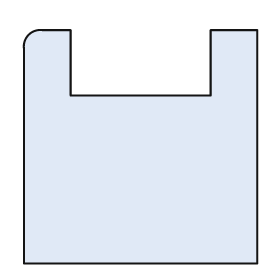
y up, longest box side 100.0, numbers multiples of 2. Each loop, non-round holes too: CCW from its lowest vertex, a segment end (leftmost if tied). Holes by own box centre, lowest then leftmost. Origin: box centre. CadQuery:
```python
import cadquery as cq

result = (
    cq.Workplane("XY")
    .moveTo(-50.0, -50.0)
    .lineTo(50.0, -50.0)
    .lineTo(50.0, 50.0)
    .lineTo(30.0, 50.0)
    .lineTo(30.0, 22.0)
    .lineTo(-30.0, 22.0)
    .lineTo(-30.0, 50.0)
    .lineTo(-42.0, 50.0)
    .threePointArc((-48.0, 48.0), (-50.0, 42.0))
    .close()
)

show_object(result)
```